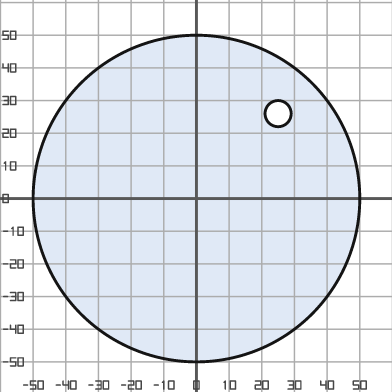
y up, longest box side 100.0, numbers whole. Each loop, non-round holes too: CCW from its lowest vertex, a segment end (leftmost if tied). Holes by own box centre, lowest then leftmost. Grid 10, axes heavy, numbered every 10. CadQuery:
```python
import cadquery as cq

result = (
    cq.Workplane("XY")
    .moveTo(0.0, 0.0)
    .circle(50.0)
    .moveTo(25.0, 26.0)
    .circle(4.0)
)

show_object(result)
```